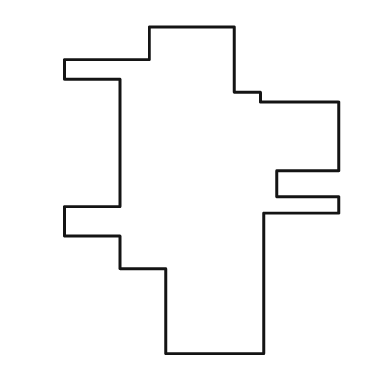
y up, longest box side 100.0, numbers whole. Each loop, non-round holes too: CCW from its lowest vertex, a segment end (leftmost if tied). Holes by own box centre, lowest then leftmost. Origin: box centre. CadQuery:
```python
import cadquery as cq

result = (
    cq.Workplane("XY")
    .moveTo(-11.0, -50.0)
    .lineTo(19.0, -50.0)
    .lineTo(19.0, -7.0)
    .lineTo(42.0, -7.0)
    .lineTo(42.0, -2.0)
    .lineTo(23.0, -2.0)
    .lineTo(23.0, 6.0)
    .lineTo(42.0, 6.0)
    .lineTo(42.0, 27.0)
    .lineTo(18.0, 27.0)
    .lineTo(18.0, 30.0)
    .lineTo(10.0, 30.0)
    .lineTo(10.0, 50.0)
    .lineTo(-16.0, 50.0)
    .lineTo(-16.0, 40.0)
    .lineTo(-42.0, 40.0)
    .lineTo(-42.0, 34.0)
    .lineTo(-25.0, 34.0)
    .lineTo(-25.0, -5.0)
    .lineTo(-42.0, -5.0)
    .lineTo(-42.0, -14.0)
    .lineTo(-25.0, -14.0)
    .lineTo(-25.0, -24.0)
    .lineTo(-11.0, -24.0)
    .close()
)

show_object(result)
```